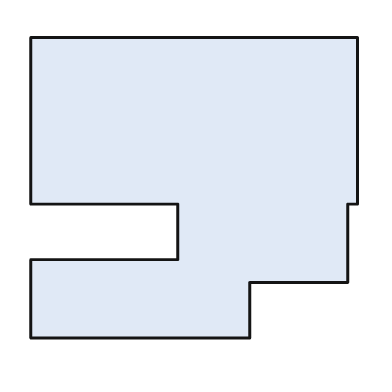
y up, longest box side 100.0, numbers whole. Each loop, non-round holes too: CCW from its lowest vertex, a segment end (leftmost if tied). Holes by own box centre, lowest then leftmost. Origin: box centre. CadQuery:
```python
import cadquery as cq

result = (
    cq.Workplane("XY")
    .moveTo(-50.0, -46.0)
    .lineTo(17.0, -46.0)
    .lineTo(17.0, -29.0)
    .lineTo(47.0, -29.0)
    .lineTo(47.0, -5.0)
    .lineTo(50.0, -5.0)
    .lineTo(50.0, 46.0)
    .lineTo(-50.0, 46.0)
    .lineTo(-50.0, -5.0)
    .lineTo(-5.0, -5.0)
    .lineTo(-5.0, -22.0)
    .lineTo(-50.0, -22.0)
    .close()
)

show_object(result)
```